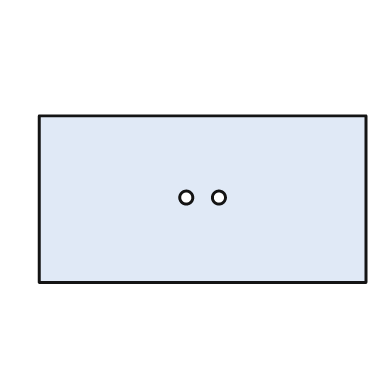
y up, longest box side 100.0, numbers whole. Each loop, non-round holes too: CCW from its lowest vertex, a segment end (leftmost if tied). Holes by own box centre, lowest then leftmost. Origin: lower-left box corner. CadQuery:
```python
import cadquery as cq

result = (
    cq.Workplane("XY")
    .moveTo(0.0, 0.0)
    .lineTo(100.0, 0.0)
    .lineTo(100.0, 51.0)
    .lineTo(0.0, 51.0)
    .close()
    .moveTo(45.0, 26.0)
    .circle(2.0)
    .moveTo(55.0, 26.0)
    .circle(2.0)
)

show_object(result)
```